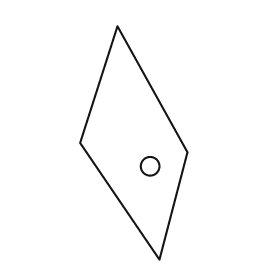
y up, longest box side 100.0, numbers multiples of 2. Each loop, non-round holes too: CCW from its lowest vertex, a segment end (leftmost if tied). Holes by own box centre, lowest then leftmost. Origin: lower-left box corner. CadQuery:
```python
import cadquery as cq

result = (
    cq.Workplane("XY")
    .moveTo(34.0, 0.0)
    .lineTo(46.0, 46.0)
    .lineTo(16.0, 100.0)
    .lineTo(0.0, 50.0)
    .close()
    .moveTo(30.0, 40.0)
    .circle(4.0)
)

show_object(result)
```